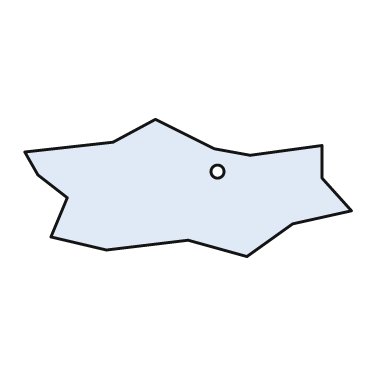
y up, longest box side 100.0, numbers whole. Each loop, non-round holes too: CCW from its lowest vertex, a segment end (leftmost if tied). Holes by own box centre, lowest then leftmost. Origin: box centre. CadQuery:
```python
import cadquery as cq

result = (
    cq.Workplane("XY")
    .moveTo(18.0, -21.0)
    .lineTo(32.0, -11.0)
    .lineTo(50.0, -7.0)
    .lineTo(41.0, 3.0)
    .lineTo(41.0, 13.0)
    .lineTo(19.0, 10.0)
    .lineTo(8.0, 12.0)
    .lineTo(-10.0, 21.0)
    .lineTo(-23.0, 14.0)
    .lineTo(-50.0, 11.0)
    .lineTo(-46.0, 4.0)
    .lineTo(-37.0, -3.0)
    .lineTo(-42.0, -15.0)
    .lineTo(-25.0, -19.0)
    .lineTo(0.0, -16.0)
    .close()
    .moveTo(9.0, 5.0)
    .circle(2.0)
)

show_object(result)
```